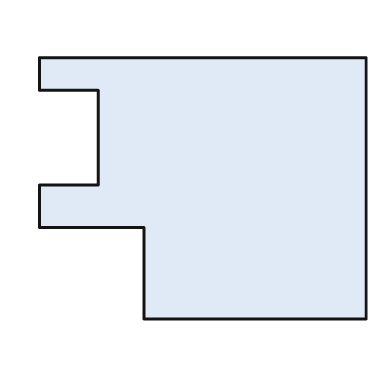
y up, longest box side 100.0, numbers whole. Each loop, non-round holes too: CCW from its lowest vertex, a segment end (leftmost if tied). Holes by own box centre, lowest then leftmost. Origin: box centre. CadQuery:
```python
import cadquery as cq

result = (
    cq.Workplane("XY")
    .moveTo(-18.0, -40.0)
    .lineTo(50.0, -40.0)
    .lineTo(50.0, 40.0)
    .lineTo(-50.0, 40.0)
    .lineTo(-50.0, 30.0)
    .lineTo(-32.0, 30.0)
    .lineTo(-32.0, 1.0)
    .lineTo(-50.0, 1.0)
    .lineTo(-50.0, -12.0)
    .lineTo(-18.0, -12.0)
    .close()
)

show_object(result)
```